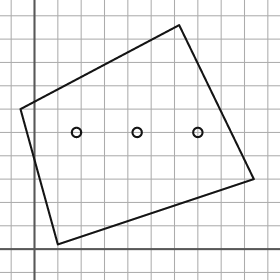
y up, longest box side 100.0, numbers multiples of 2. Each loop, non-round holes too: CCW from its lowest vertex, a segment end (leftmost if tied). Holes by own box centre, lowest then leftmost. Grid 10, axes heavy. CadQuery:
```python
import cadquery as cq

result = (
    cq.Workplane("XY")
    .moveTo(10.0, 2.0)
    .lineTo(94.0, 30.0)
    .lineTo(62.0, 96.0)
    .lineTo(-6.0, 60.0)
    .close()
    .moveTo(18.0, 50.0)
    .circle(2.0)
    .moveTo(44.0, 50.0)
    .circle(2.0)
    .moveTo(70.0, 50.0)
    .circle(2.0)
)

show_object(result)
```